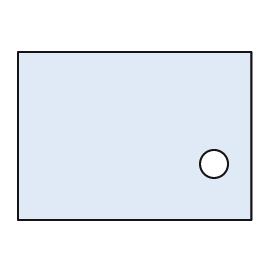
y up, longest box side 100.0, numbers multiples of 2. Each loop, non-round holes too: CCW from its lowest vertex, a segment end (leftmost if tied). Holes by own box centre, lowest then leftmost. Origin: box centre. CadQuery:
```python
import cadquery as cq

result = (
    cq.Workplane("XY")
    .moveTo(-50.0, -36.0)
    .lineTo(50.0, -36.0)
    .lineTo(50.0, 36.0)
    .lineTo(-50.0, 36.0)
    .close()
    .moveTo(34.0, -12.0)
    .circle(6.0)
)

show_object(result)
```